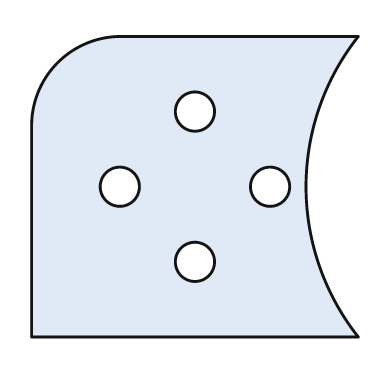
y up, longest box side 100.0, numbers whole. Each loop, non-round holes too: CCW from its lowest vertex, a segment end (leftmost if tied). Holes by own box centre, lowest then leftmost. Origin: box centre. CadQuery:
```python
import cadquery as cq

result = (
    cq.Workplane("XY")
    .moveTo(-50.0, -46.0)
    .lineTo(50.0, -46.0)
    .threePointArc((34.0, 0.0), (50.0, 46.0))
    .lineTo(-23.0, 46.0)
    .threePointArc((-42.0, 38.0), (-50.0, 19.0))
    .close()
    .moveTo(0.0, -23.0)
    .circle(6.0)
    .moveTo(-23.0, 0.0)
    .circle(6.0)
    .moveTo(23.0, 0.0)
    .circle(6.0)
    .moveTo(0.0, 23.0)
    .circle(6.0)
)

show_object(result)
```